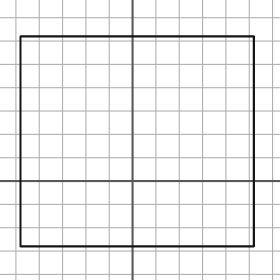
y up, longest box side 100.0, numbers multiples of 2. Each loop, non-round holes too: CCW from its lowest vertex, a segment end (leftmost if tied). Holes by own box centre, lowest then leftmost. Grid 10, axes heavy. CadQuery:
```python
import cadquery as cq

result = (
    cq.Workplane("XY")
    .moveTo(-48.0, -28.0)
    .lineTo(52.0, -28.0)
    .lineTo(52.0, 62.0)
    .lineTo(-48.0, 62.0)
    .close()
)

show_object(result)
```